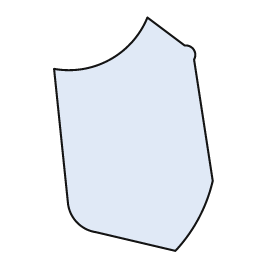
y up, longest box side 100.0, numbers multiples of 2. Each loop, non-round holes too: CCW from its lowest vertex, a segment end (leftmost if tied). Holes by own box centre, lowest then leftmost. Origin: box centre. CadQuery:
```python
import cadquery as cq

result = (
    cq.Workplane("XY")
    .moveTo(18.0, -50.0)
    .threePointArc((28.0, -36.0), (34.0, -20.0))
    .lineTo(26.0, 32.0)
    .threePointArc((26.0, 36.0), (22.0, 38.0))
    .lineTo(6.0, 50.0)
    .threePointArc((-10.0, 32.0), (-34.0, 28.0))
    .lineTo(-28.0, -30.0)
    .threePointArc((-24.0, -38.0), (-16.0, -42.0))
    .close()
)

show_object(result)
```